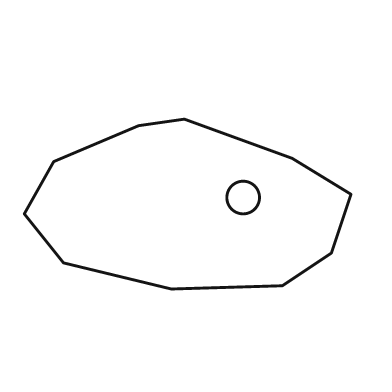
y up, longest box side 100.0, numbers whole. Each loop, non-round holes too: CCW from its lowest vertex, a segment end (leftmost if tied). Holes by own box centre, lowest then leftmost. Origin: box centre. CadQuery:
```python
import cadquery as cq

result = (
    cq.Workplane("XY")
    .moveTo(-5.0, -26.0)
    .lineTo(29.0, -25.0)
    .lineTo(44.0, -15.0)
    .lineTo(50.0, 3.0)
    .lineTo(32.0, 14.0)
    .lineTo(-1.0, 26.0)
    .lineTo(-15.0, 24.0)
    .lineTo(-41.0, 13.0)
    .lineTo(-50.0, -3.0)
    .lineTo(-38.0, -18.0)
    .close()
    .moveTo(17.0, 2.0)
    .circle(5.0)
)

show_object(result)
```